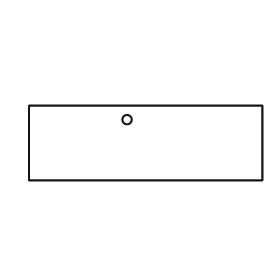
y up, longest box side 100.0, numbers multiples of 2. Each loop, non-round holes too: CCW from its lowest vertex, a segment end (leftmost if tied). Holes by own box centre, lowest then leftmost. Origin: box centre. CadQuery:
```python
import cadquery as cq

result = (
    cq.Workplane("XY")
    .moveTo(-50.0, -16.0)
    .lineTo(50.0, -16.0)
    .lineTo(50.0, 16.0)
    .lineTo(-50.0, 16.0)
    .close()
    .moveTo(-8.0, 10.0)
    .circle(2.0)
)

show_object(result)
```